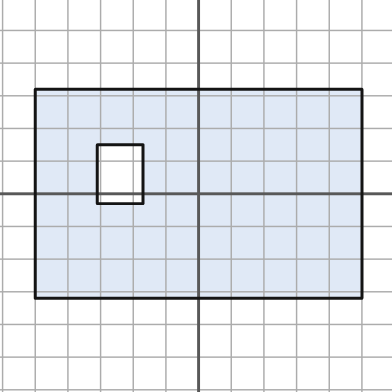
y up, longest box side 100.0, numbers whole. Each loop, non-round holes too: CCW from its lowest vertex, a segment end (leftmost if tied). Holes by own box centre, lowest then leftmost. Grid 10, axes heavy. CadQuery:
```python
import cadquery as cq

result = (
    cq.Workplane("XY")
    .moveTo(-50.0, -32.0)
    .lineTo(50.0, -32.0)
    .lineTo(50.0, 32.0)
    .lineTo(-50.0, 32.0)
    .close()
    .moveTo(-31.0, -3.0)
    .lineTo(-17.0, -3.0)
    .lineTo(-17.0, 15.0)
    .lineTo(-31.0, 15.0)
    .close()
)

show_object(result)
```